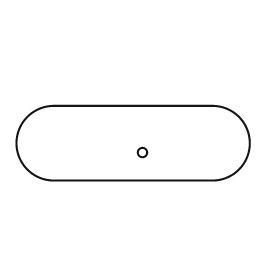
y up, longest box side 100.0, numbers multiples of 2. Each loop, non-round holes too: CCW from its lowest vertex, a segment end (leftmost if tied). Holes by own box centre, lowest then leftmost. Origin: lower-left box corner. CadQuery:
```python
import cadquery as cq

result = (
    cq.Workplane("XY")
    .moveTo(16.0, 0.0)
    .lineTo(84.0, 0.0)
    .threePointArc((100.0, 16.0), (84.0, 32.0))
    .lineTo(16.0, 32.0)
    .threePointArc((0.0, 16.0), (16.0, 0.0))
    .close()
    .moveTo(54.0, 12.0)
    .circle(2.0)
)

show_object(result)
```